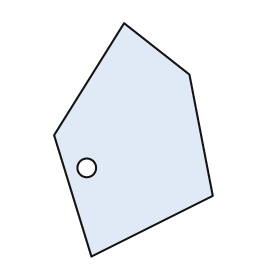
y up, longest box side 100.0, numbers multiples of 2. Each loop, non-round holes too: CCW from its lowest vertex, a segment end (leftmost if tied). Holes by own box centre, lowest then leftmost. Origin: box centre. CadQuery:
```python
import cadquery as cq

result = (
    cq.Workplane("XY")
    .moveTo(-18.0, -50.0)
    .lineTo(34.0, -24.0)
    .lineTo(24.0, 28.0)
    .lineTo(-4.0, 50.0)
    .lineTo(-34.0, 2.0)
    .close()
    .moveTo(-20.0, -12.0)
    .circle(4.0)
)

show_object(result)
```